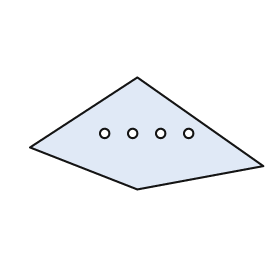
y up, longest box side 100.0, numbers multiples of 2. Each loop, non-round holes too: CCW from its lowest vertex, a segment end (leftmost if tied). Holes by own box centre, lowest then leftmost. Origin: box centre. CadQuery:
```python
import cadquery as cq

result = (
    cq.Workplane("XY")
    .moveTo(-4.0, -24.0)
    .lineTo(50.0, -14.0)
    .lineTo(-4.0, 24.0)
    .lineTo(-50.0, -6.0)
    .close()
    .moveTo(-18.0, 0.0)
    .circle(2.0)
    .moveTo(-6.0, 0.0)
    .circle(2.0)
    .moveTo(6.0, 0.0)
    .circle(2.0)
    .moveTo(18.0, 0.0)
    .circle(2.0)
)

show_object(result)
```